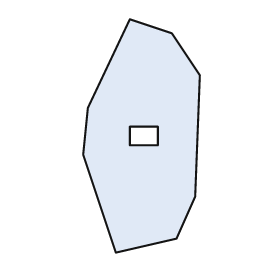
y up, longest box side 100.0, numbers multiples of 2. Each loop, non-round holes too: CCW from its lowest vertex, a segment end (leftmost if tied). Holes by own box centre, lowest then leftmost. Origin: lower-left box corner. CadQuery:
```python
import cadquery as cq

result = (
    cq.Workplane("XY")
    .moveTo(14.0, 0.0)
    .lineTo(40.0, 6.0)
    .lineTo(48.0, 24.0)
    .lineTo(50.0, 76.0)
    .lineTo(38.0, 94.0)
    .lineTo(20.0, 100.0)
    .lineTo(2.0, 62.0)
    .lineTo(0.0, 42.0)
    .close()
    .moveTo(20.0, 46.0)
    .lineTo(32.0, 46.0)
    .lineTo(32.0, 54.0)
    .lineTo(20.0, 54.0)
    .close()
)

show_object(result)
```